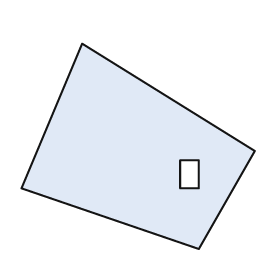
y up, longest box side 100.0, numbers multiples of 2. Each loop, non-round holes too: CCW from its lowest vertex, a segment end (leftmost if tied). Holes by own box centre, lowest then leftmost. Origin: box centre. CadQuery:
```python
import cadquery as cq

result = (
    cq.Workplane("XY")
    .moveTo(26.0, -44.0)
    .lineTo(50.0, -2.0)
    .lineTo(-24.0, 44.0)
    .lineTo(-50.0, -18.0)
    .close()
    .moveTo(18.0, -18.0)
    .lineTo(26.0, -18.0)
    .lineTo(26.0, -6.0)
    .lineTo(18.0, -6.0)
    .close()
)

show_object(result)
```